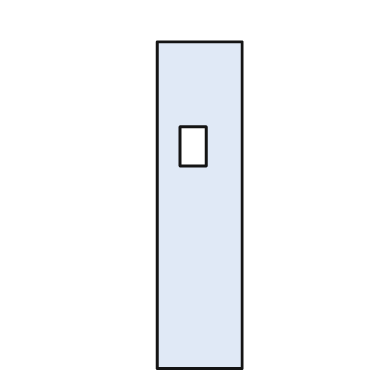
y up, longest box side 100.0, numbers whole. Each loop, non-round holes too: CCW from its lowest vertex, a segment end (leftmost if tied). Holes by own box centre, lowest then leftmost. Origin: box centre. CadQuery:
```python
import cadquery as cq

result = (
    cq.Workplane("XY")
    .moveTo(-13.0, -50.0)
    .lineTo(13.0, -50.0)
    .lineTo(13.0, 50.0)
    .lineTo(-13.0, 50.0)
    .close()
    .moveTo(-6.0, 12.0)
    .lineTo(2.0, 12.0)
    .lineTo(2.0, 24.0)
    .lineTo(-6.0, 24.0)
    .close()
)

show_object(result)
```